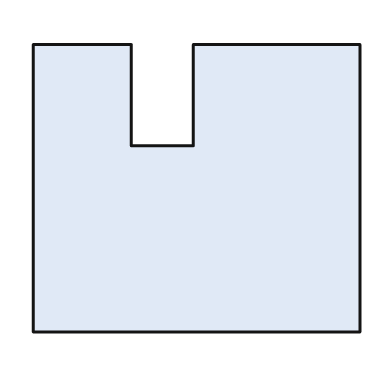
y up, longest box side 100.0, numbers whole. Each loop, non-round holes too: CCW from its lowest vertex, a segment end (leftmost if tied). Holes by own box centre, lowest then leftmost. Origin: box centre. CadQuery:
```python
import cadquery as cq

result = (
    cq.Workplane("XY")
    .moveTo(-50.0, -44.0)
    .lineTo(50.0, -44.0)
    .lineTo(50.0, 44.0)
    .lineTo(-1.0, 44.0)
    .lineTo(-1.0, 13.0)
    .lineTo(-20.0, 13.0)
    .lineTo(-20.0, 44.0)
    .lineTo(-50.0, 44.0)
    .close()
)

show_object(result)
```